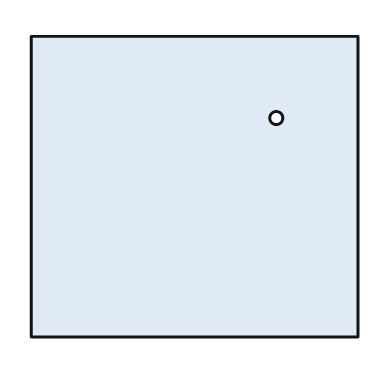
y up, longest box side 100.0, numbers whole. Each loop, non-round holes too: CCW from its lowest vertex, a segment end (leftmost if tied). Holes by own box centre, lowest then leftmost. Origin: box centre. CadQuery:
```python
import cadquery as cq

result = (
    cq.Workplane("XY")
    .moveTo(-50.0, -46.0)
    .lineTo(50.0, -46.0)
    .lineTo(50.0, 46.0)
    .lineTo(-50.0, 46.0)
    .close()
    .moveTo(25.0, 21.0)
    .circle(2.0)
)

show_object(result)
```